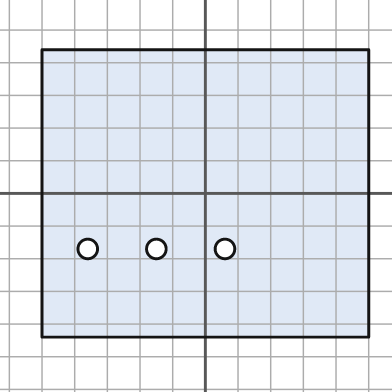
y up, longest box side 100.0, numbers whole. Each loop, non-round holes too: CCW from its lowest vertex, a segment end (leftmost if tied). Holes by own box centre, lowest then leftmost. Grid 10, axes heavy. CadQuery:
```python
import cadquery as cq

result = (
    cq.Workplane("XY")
    .moveTo(-50.0, -44.0)
    .lineTo(50.0, -44.0)
    .lineTo(50.0, 44.0)
    .lineTo(-50.0, 44.0)
    .close()
    .moveTo(-36.0, -17.0)
    .circle(3.0)
    .moveTo(-15.0, -17.0)
    .circle(3.0)
    .moveTo(6.0, -17.0)
    .circle(3.0)
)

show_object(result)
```